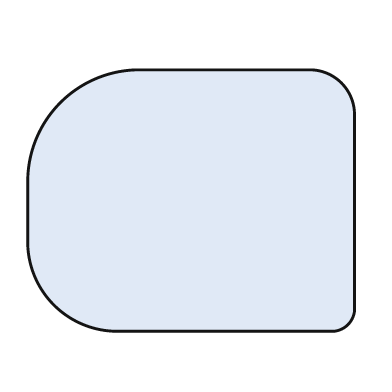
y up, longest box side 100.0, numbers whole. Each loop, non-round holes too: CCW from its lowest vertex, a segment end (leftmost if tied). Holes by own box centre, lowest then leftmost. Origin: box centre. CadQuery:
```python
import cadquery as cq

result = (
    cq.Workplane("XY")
    .moveTo(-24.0, -40.0)
    .lineTo(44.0, -40.0)
    .threePointArc((48.0, -38.0), (50.0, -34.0))
    .lineTo(50.0, 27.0)
    .threePointArc((46.0, 36.0), (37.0, 40.0))
    .lineTo(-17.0, 40.0)
    .threePointArc((-40.0, 30.0), (-50.0, 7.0))
    .lineTo(-50.0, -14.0)
    .threePointArc((-42.0, -32.0), (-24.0, -40.0))
    .close()
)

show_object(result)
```